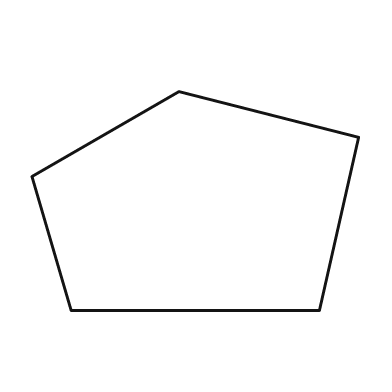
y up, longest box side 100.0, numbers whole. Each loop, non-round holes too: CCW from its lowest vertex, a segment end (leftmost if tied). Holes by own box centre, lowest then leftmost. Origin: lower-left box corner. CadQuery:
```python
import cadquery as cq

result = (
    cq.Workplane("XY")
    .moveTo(12.0, 0.0)
    .lineTo(88.0, 0.0)
    .lineTo(100.0, 53.0)
    .lineTo(45.0, 67.0)
    .lineTo(0.0, 41.0)
    .close()
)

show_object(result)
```